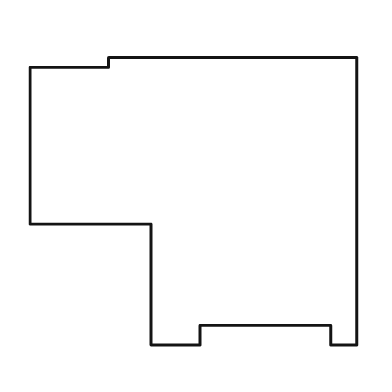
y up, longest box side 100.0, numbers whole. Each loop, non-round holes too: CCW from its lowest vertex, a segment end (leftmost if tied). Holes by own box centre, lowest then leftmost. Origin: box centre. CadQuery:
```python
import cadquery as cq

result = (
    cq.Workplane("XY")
    .moveTo(-13.0, -44.0)
    .lineTo(2.0, -44.0)
    .lineTo(2.0, -38.0)
    .lineTo(42.0, -38.0)
    .lineTo(42.0, -44.0)
    .lineTo(50.0, -44.0)
    .lineTo(50.0, 44.0)
    .lineTo(-26.0, 44.0)
    .lineTo(-26.0, 41.0)
    .lineTo(-50.0, 41.0)
    .lineTo(-50.0, -7.0)
    .lineTo(-13.0, -7.0)
    .close()
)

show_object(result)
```